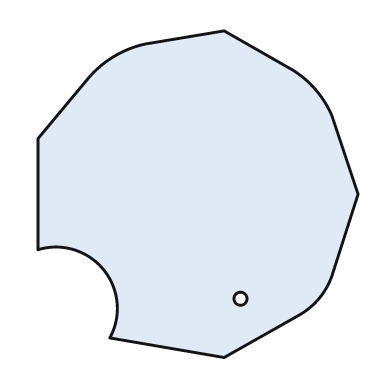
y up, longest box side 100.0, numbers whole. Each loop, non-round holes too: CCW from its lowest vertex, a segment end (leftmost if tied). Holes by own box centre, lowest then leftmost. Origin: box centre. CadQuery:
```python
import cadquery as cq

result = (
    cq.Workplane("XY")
    .moveTo(8.0, -50.0)
    .lineTo(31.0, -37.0)
    .threePointArc((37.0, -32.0), (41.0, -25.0))
    .lineTo(49.0, 0.0)
    .lineTo(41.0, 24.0)
    .threePointArc((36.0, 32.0), (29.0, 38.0))
    .lineTo(8.0, 50.0)
    .lineTo(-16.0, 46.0)
    .threePointArc((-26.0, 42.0), (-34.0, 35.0))
    .lineTo(-49.0, 17.0)
    .lineTo(-49.0, -17.0)
    .threePointArc((-29.0, -23.0), (-27.0, -44.0))
    .close()
    .moveTo(13.0, -32.0)
    .circle(2.0)
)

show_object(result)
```